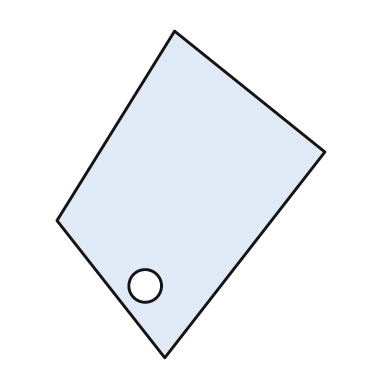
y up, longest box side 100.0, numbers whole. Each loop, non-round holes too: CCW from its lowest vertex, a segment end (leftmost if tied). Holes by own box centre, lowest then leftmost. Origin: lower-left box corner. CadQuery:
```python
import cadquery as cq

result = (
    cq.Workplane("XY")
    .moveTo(33.0, 0.0)
    .lineTo(82.0, 63.0)
    .lineTo(36.0, 100.0)
    .lineTo(0.0, 42.0)
    .close()
    .moveTo(27.0, 22.0)
    .circle(5.0)
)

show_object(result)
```